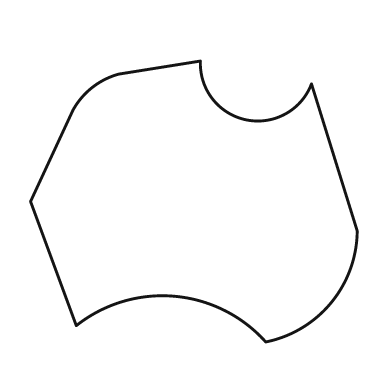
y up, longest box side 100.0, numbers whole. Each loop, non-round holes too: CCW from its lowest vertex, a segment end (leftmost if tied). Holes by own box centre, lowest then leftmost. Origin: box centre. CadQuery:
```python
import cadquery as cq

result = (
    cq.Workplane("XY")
    .moveTo(22.0, -43.0)
    .threePointArc((42.0, -31.0), (50.0, -9.0))
    .lineTo(36.0, 36.0)
    .threePointArc((16.0, 25.0), (2.0, 43.0))
    .lineTo(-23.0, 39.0)
    .threePointArc((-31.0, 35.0), (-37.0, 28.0))
    .lineTo(-50.0, 0.0)
    .lineTo(-36.0, -38.0)
    .threePointArc((-6.0, -29.0), (22.0, -43.0))
    .close()
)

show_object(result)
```